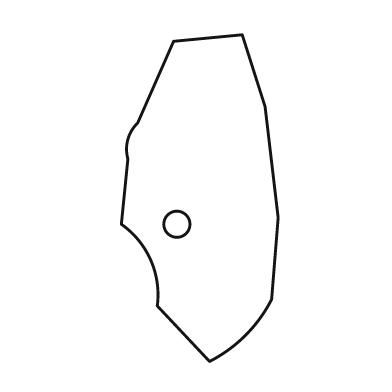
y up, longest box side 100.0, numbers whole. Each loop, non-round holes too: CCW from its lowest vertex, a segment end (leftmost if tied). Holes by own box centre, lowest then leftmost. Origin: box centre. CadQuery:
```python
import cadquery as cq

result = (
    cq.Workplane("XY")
    .moveTo(3.0, -50.0)
    .threePointArc((14.0, -42.0), (22.0, -31.0))
    .lineTo(24.0, -6.0)
    .lineTo(20.0, 28.0)
    .lineTo(13.0, 50.0)
    .lineTo(-8.0, 48.0)
    .lineTo(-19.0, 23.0)
    .threePointArc((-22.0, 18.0), (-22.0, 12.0))
    .lineTo(-24.0, -8.0)
    .threePointArc((-15.0, -19.0), (-13.0, -33.0))
    .close()
    .moveTo(-7.0, -8.0)
    .circle(4.0)
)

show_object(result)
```